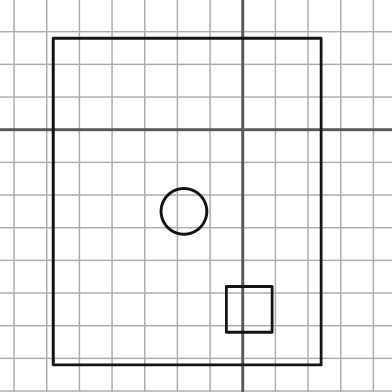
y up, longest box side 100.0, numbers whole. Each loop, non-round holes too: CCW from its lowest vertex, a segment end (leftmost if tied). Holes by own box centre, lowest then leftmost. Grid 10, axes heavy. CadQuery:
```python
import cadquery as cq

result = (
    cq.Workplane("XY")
    .moveTo(-58.0, -72.0)
    .lineTo(24.0, -72.0)
    .lineTo(24.0, 28.0)
    .lineTo(-58.0, 28.0)
    .close()
    .moveTo(-5.0, -62.0)
    .lineTo(9.0, -62.0)
    .lineTo(9.0, -48.0)
    .lineTo(-5.0, -48.0)
    .close()
    .moveTo(-18.0, -25.0)
    .circle(7.0)
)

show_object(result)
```